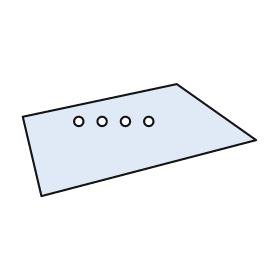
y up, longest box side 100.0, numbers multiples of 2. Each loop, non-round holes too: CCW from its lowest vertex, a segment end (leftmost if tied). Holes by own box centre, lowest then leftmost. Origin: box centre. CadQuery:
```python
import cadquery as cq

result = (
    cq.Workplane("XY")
    .moveTo(-42.0, -24.0)
    .lineTo(50.0, 0.0)
    .lineTo(16.0, 24.0)
    .lineTo(-50.0, 10.0)
    .close()
    .moveTo(-26.0, 8.0)
    .circle(2.0)
    .moveTo(-16.0, 8.0)
    .circle(2.0)
    .moveTo(-6.0, 8.0)
    .circle(2.0)
    .moveTo(4.0, 8.0)
    .circle(2.0)
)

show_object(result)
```